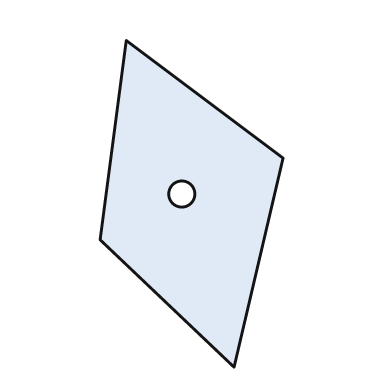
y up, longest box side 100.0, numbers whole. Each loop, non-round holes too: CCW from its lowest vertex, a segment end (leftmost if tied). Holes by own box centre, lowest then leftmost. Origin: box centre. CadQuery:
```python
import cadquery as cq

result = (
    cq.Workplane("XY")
    .moveTo(13.0, -50.0)
    .lineTo(28.0, 14.0)
    .lineTo(-20.0, 50.0)
    .lineTo(-28.0, -11.0)
    .close()
    .moveTo(-3.0, 3.0)
    .circle(4.0)
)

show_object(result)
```